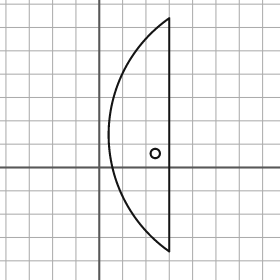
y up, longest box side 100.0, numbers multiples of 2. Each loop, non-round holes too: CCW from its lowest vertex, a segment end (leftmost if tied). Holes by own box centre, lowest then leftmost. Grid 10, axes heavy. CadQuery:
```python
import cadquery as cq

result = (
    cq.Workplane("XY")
    .moveTo(30.0, -36.0)
    .lineTo(30.0, 64.0)
    .threePointArc((4.0, 14.0), (30.0, -36.0))
    .close()
    .moveTo(24.0, 6.0)
    .circle(2.0)
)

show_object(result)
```